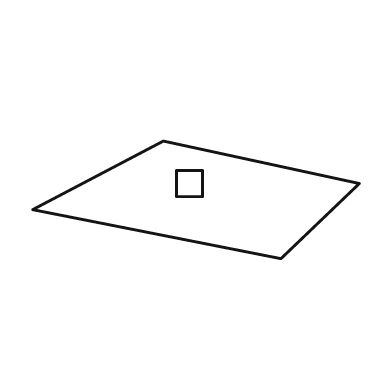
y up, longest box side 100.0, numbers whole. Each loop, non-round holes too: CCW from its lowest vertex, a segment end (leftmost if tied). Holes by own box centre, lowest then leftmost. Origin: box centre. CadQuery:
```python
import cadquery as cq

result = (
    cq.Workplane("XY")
    .moveTo(26.0, -18.0)
    .lineTo(50.0, 5.0)
    .lineTo(-10.0, 18.0)
    .lineTo(-50.0, -3.0)
    .close()
    .moveTo(-6.0, 1.0)
    .lineTo(2.0, 1.0)
    .lineTo(2.0, 9.0)
    .lineTo(-6.0, 9.0)
    .close()
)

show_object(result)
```